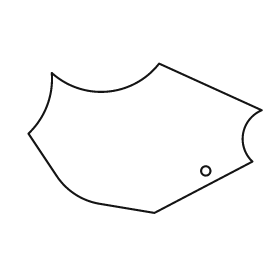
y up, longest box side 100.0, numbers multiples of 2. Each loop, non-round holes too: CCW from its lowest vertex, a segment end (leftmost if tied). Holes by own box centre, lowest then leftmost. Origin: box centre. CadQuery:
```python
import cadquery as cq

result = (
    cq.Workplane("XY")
    .moveTo(4.0, -32.0)
    .lineTo(46.0, -10.0)
    .threePointArc((42.0, 2.0), (50.0, 12.0))
    .lineTo(6.0, 32.0)
    .threePointArc((-16.0, 20.0), (-40.0, 28.0))
    .threePointArc((-42.0, 14.0), (-50.0, 2.0))
    .lineTo(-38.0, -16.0)
    .threePointArc((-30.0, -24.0), (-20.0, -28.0))
    .close()
    .moveTo(26.0, -14.0)
    .circle(2.0)
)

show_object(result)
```